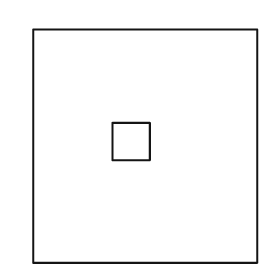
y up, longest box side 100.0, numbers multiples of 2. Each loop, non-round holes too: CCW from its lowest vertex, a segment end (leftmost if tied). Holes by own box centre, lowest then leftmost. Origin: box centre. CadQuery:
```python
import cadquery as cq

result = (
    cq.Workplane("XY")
    .moveTo(-48.0, -50.0)
    .lineTo(48.0, -50.0)
    .lineTo(48.0, 50.0)
    .lineTo(-48.0, 50.0)
    .close()
    .moveTo(-14.0, -6.0)
    .lineTo(2.0, -6.0)
    .lineTo(2.0, 10.0)
    .lineTo(-14.0, 10.0)
    .close()
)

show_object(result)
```